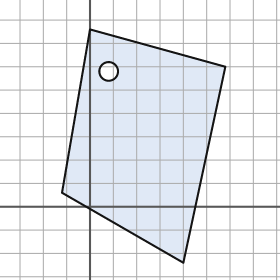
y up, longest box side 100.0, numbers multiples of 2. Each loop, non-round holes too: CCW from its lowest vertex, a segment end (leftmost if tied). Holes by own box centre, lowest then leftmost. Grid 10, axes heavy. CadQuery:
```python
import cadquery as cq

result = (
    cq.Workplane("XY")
    .moveTo(40.0, -24.0)
    .lineTo(58.0, 60.0)
    .lineTo(0.0, 76.0)
    .lineTo(-12.0, 6.0)
    .close()
    .moveTo(8.0, 58.0)
    .circle(4.0)
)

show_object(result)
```